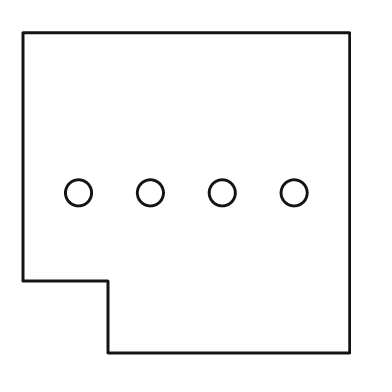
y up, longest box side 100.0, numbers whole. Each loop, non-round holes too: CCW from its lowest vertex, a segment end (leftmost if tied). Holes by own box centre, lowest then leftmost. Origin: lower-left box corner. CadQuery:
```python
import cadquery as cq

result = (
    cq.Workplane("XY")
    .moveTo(26.0, 0.0)
    .lineTo(100.0, 0.0)
    .lineTo(100.0, 98.0)
    .lineTo(0.0, 98.0)
    .lineTo(0.0, 22.0)
    .lineTo(26.0, 22.0)
    .close()
    .moveTo(17.0, 49.0)
    .circle(4.0)
    .moveTo(39.0, 49.0)
    .circle(4.0)
    .moveTo(61.0, 49.0)
    .circle(4.0)
    .moveTo(83.0, 49.0)
    .circle(4.0)
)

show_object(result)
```